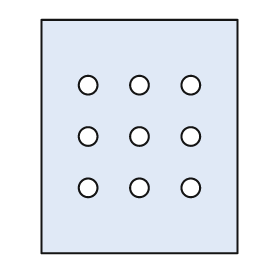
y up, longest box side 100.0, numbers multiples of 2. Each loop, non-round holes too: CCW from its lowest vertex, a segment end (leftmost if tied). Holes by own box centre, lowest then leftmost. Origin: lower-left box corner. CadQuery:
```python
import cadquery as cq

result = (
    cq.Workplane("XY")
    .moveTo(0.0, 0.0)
    .lineTo(84.0, 0.0)
    .lineTo(84.0, 100.0)
    .lineTo(0.0, 100.0)
    .close()
    .moveTo(20.0, 28.0)
    .circle(4.0)
    .moveTo(42.0, 28.0)
    .circle(4.0)
    .moveTo(64.0, 28.0)
    .circle(4.0)
    .moveTo(20.0, 50.0)
    .circle(4.0)
    .moveTo(42.0, 50.0)
    .circle(4.0)
    .moveTo(64.0, 50.0)
    .circle(4.0)
    .moveTo(20.0, 72.0)
    .circle(4.0)
    .moveTo(42.0, 72.0)
    .circle(4.0)
    .moveTo(64.0, 72.0)
    .circle(4.0)
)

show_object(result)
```